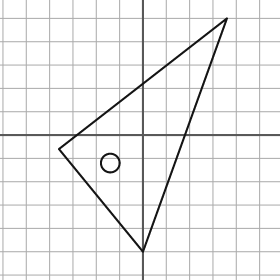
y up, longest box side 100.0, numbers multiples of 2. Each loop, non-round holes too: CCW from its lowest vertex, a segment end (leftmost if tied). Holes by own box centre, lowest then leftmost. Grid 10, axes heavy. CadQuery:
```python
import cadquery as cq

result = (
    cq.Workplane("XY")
    .moveTo(0.0, -50.0)
    .lineTo(36.0, 50.0)
    .lineTo(-36.0, -6.0)
    .close()
    .moveTo(-14.0, -12.0)
    .circle(4.0)
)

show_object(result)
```